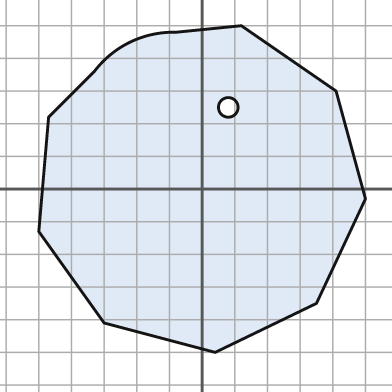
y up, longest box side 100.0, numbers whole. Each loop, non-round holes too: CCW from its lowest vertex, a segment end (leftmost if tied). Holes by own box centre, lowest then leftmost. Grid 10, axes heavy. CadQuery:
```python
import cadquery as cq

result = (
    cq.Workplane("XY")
    .moveTo(4.0, -50.0)
    .lineTo(35.0, -35.0)
    .lineTo(50.0, -3.0)
    .lineTo(41.0, 30.0)
    .lineTo(12.0, 50.0)
    .lineTo(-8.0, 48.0)
    .threePointArc((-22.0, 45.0), (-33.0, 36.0))
    .lineTo(-47.0, 22.0)
    .lineTo(-50.0, -13.0)
    .lineTo(-30.0, -41.0)
    .close()
    .moveTo(8.0, 25.0)
    .circle(3.0)
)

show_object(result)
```